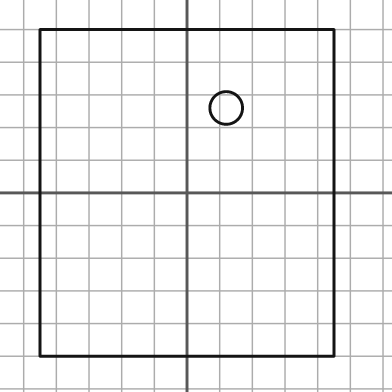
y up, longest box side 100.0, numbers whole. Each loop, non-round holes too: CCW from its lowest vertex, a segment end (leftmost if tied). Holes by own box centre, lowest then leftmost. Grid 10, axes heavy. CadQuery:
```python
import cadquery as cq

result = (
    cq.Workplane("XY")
    .moveTo(-45.0, -50.0)
    .lineTo(45.0, -50.0)
    .lineTo(45.0, 50.0)
    .lineTo(-45.0, 50.0)
    .close()
    .moveTo(12.0, 26.0)
    .circle(5.0)
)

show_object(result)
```